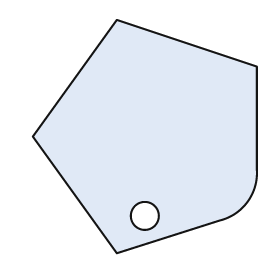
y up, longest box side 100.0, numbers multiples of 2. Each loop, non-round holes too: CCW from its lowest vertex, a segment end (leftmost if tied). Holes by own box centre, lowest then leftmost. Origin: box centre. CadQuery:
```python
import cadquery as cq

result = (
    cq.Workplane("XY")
    .moveTo(-12.0, -50.0)
    .lineTo(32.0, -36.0)
    .threePointArc((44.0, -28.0), (48.0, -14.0))
    .lineTo(48.0, 30.0)
    .lineTo(-12.0, 50.0)
    .lineTo(-48.0, 0.0)
    .close()
    .moveTo(0.0, -34.0)
    .circle(6.0)
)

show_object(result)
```